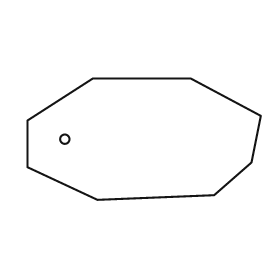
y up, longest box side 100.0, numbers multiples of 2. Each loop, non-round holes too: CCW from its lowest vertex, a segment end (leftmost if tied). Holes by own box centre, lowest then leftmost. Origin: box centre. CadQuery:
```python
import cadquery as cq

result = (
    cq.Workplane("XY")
    .moveTo(-20.0, -26.0)
    .lineTo(30.0, -24.0)
    .lineTo(46.0, -10.0)
    .lineTo(50.0, 10.0)
    .lineTo(20.0, 26.0)
    .lineTo(-22.0, 26.0)
    .lineTo(-50.0, 8.0)
    .lineTo(-50.0, -12.0)
    .close()
    .moveTo(-34.0, 0.0)
    .circle(2.0)
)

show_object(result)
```